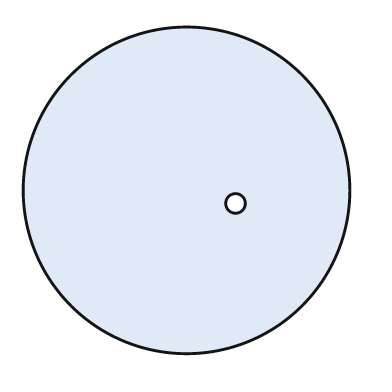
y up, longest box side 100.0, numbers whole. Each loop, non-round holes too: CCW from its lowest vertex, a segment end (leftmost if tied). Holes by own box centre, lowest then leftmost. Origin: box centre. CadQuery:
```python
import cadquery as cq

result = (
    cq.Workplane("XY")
    .moveTo(0.0, 0.0)
    .circle(50.0)
    .moveTo(15.0, -4.0)
    .circle(3.0)
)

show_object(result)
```